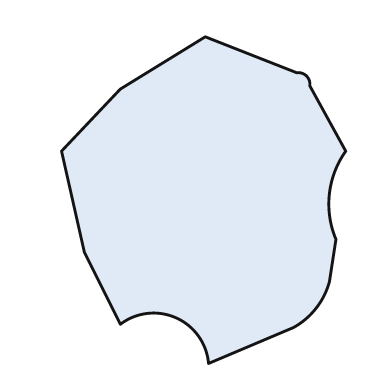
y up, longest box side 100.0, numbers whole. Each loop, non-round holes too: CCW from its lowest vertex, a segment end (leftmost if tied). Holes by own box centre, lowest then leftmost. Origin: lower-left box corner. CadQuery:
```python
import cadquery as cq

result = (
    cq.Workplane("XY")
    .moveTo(45.0, 0.0)
    .lineTo(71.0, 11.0)
    .threePointArc((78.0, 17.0), (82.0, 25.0))
    .lineTo(84.0, 38.0)
    .threePointArc((82.0, 52.0), (87.0, 65.0))
    .lineTo(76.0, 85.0)
    .threePointArc((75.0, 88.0), (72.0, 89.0))
    .lineTo(44.0, 100.0)
    .lineTo(18.0, 84.0)
    .lineTo(0.0, 65.0)
    .lineTo(7.0, 34.0)
    .lineTo(18.0, 12.0)
    .threePointArc((35.0, 14.0), (45.0, 0.0))
    .close()
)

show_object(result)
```